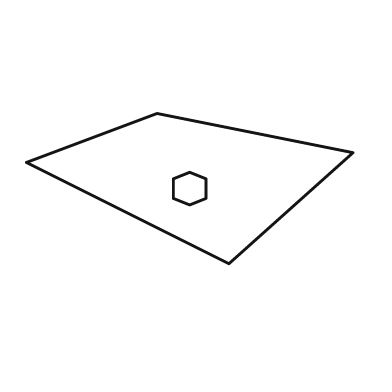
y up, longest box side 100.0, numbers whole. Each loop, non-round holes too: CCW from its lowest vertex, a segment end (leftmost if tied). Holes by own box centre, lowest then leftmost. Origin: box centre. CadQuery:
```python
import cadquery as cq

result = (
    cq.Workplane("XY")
    .moveTo(12.0, -23.0)
    .lineTo(50.0, 11.0)
    .lineTo(-10.0, 23.0)
    .lineTo(-50.0, 8.0)
    .close()
    .moveTo(0.0, -5.0)
    .lineTo(5.0, -3.0)
    .lineTo(5.0, 3.0)
    .lineTo(0.0, 5.0)
    .lineTo(-5.0, 3.0)
    .lineTo(-5.0, -3.0)
    .close()
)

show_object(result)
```